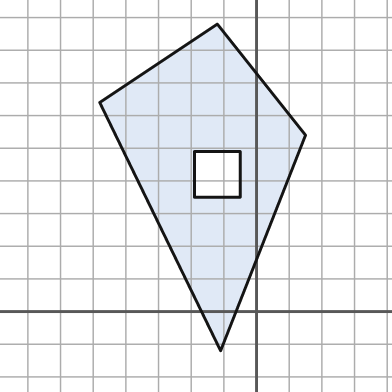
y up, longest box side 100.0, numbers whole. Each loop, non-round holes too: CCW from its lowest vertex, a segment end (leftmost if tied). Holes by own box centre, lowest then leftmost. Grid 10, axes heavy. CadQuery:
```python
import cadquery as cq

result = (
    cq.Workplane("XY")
    .moveTo(-11.0, -12.0)
    .lineTo(15.0, 54.0)
    .lineTo(-12.0, 88.0)
    .lineTo(-48.0, 64.0)
    .close()
    .moveTo(-19.0, 35.0)
    .lineTo(-5.0, 35.0)
    .lineTo(-5.0, 49.0)
    .lineTo(-19.0, 49.0)
    .close()
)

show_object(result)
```